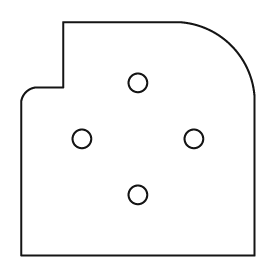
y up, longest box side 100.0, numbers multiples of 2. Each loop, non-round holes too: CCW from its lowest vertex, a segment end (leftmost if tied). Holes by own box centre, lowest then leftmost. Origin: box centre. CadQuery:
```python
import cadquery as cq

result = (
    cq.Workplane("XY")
    .moveTo(-50.0, -50.0)
    .lineTo(50.0, -50.0)
    .lineTo(50.0, 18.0)
    .threePointArc((40.0, 40.0), (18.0, 50.0))
    .lineTo(-32.0, 50.0)
    .lineTo(-32.0, 22.0)
    .lineTo(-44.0, 22.0)
    .threePointArc((-48.0, 20.0), (-50.0, 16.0))
    .close()
    .moveTo(0.0, -24.0)
    .circle(4.0)
    .moveTo(-24.0, 0.0)
    .circle(4.0)
    .moveTo(24.0, 0.0)
    .circle(4.0)
    .moveTo(0.0, 24.0)
    .circle(4.0)
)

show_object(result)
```